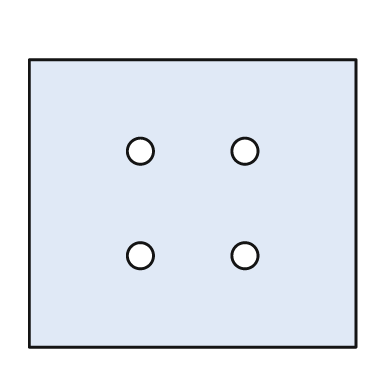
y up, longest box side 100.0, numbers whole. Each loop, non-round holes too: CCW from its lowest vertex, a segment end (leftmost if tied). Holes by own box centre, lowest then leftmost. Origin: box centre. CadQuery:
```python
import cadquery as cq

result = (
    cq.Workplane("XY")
    .moveTo(-50.0, -44.0)
    .lineTo(50.0, -44.0)
    .lineTo(50.0, 44.0)
    .lineTo(-50.0, 44.0)
    .close()
    .moveTo(-16.0, -16.0)
    .circle(4.0)
    .moveTo(16.0, -16.0)
    .circle(4.0)
    .moveTo(-16.0, 16.0)
    .circle(4.0)
    .moveTo(16.0, 16.0)
    .circle(4.0)
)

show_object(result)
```